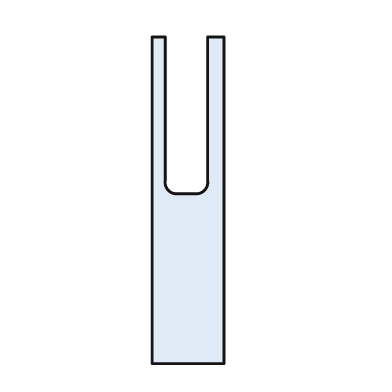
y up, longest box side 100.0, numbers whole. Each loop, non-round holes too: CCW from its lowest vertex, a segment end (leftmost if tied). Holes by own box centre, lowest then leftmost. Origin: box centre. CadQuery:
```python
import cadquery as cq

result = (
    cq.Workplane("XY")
    .moveTo(-11.0, -50.0)
    .lineTo(11.0, -50.0)
    .lineTo(11.0, 50.0)
    .lineTo(6.0, 50.0)
    .lineTo(6.0, 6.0)
    .threePointArc((5.0, 3.0), (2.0, 2.0))
    .lineTo(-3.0, 2.0)
    .threePointArc((-6.0, 3.0), (-7.0, 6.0))
    .lineTo(-7.0, 50.0)
    .lineTo(-11.0, 50.0)
    .close()
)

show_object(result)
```